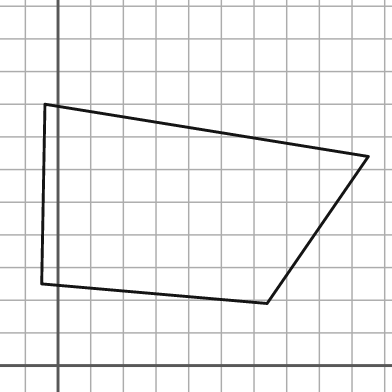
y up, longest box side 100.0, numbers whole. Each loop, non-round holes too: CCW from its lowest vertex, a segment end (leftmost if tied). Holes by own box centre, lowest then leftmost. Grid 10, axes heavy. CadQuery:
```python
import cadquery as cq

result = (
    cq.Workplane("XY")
    .moveTo(64.0, 19.0)
    .lineTo(95.0, 64.0)
    .lineTo(-4.0, 80.0)
    .lineTo(-5.0, 25.0)
    .close()
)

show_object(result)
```